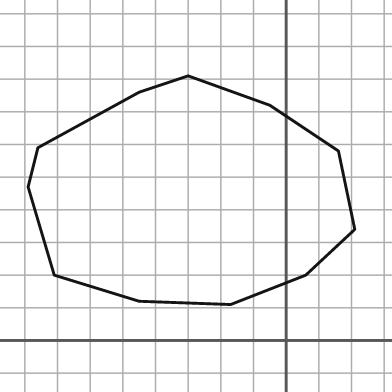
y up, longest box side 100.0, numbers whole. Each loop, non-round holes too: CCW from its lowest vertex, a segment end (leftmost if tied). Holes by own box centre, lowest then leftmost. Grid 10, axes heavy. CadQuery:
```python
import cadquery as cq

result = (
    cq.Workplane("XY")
    .moveTo(-17.0, 11.0)
    .lineTo(6.0, 20.0)
    .lineTo(21.0, 34.0)
    .lineTo(16.0, 58.0)
    .lineTo(-5.0, 72.0)
    .lineTo(-30.0, 81.0)
    .lineTo(-45.0, 76.0)
    .lineTo(-76.0, 59.0)
    .lineTo(-79.0, 47.0)
    .lineTo(-71.0, 20.0)
    .lineTo(-45.0, 12.0)
    .close()
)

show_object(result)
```